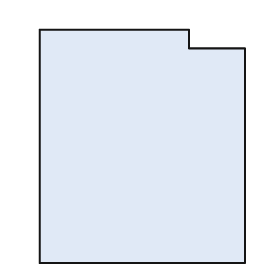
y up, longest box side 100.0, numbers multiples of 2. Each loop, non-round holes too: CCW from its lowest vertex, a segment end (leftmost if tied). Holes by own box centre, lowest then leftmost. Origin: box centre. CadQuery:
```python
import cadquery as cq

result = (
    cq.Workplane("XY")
    .moveTo(-44.0, -50.0)
    .lineTo(44.0, -50.0)
    .lineTo(44.0, 42.0)
    .lineTo(20.0, 42.0)
    .lineTo(20.0, 50.0)
    .lineTo(-44.0, 50.0)
    .close()
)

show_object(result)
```